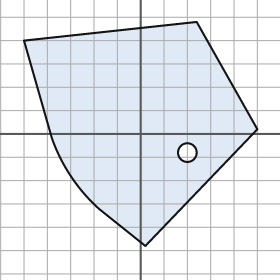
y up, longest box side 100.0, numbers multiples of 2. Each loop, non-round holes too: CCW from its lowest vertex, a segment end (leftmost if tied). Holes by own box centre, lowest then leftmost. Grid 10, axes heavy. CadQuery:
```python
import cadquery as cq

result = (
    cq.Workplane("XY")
    .moveTo(2.0, -48.0)
    .lineTo(50.0, 2.0)
    .lineTo(24.0, 48.0)
    .lineTo(-50.0, 40.0)
    .lineTo(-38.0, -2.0)
    .threePointArc((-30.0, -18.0), (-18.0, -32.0))
    .close()
    .moveTo(20.0, -8.0)
    .circle(4.0)
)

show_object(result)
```